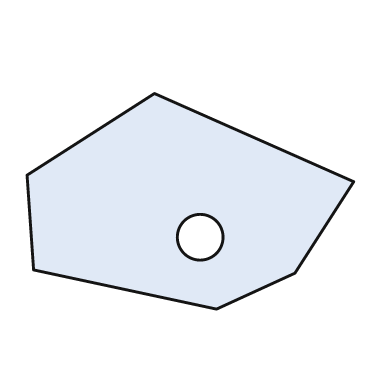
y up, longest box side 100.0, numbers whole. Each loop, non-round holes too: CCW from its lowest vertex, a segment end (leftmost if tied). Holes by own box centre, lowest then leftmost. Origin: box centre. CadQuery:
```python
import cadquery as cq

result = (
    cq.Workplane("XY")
    .moveTo(8.0, -33.0)
    .lineTo(32.0, -22.0)
    .lineTo(50.0, 6.0)
    .lineTo(-11.0, 33.0)
    .lineTo(-50.0, 8.0)
    .lineTo(-48.0, -21.0)
    .close()
    .moveTo(3.0, -11.0)
    .circle(7.0)
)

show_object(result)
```